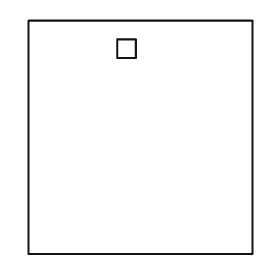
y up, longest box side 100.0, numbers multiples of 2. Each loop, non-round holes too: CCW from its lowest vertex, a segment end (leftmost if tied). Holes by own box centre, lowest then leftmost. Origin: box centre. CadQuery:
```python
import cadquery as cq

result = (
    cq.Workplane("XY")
    .moveTo(-48.0, -50.0)
    .lineTo(48.0, -50.0)
    .lineTo(48.0, 50.0)
    .lineTo(-48.0, 50.0)
    .close()
    .moveTo(-10.0, 34.0)
    .lineTo(-2.0, 34.0)
    .lineTo(-2.0, 42.0)
    .lineTo(-10.0, 42.0)
    .close()
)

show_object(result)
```